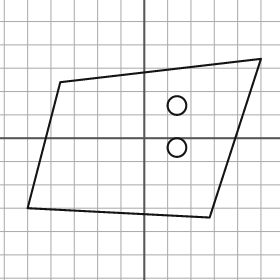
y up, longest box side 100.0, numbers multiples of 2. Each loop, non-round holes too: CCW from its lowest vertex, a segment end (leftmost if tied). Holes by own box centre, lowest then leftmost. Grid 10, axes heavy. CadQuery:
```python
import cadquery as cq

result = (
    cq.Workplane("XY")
    .moveTo(28.0, -34.0)
    .lineTo(50.0, 34.0)
    .lineTo(-36.0, 24.0)
    .lineTo(-50.0, -30.0)
    .close()
    .moveTo(14.0, -4.0)
    .circle(4.0)
    .moveTo(14.0, 14.0)
    .circle(4.0)
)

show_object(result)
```